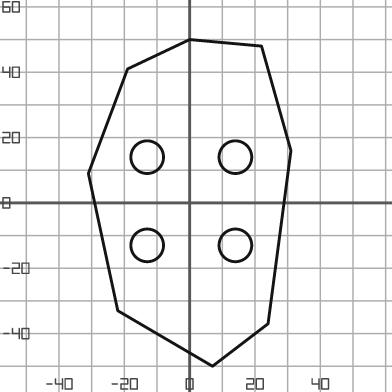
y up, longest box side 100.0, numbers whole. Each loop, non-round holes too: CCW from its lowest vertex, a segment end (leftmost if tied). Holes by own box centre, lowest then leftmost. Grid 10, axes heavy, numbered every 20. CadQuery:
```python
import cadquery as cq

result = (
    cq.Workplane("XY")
    .moveTo(7.0, -50.0)
    .lineTo(24.0, -37.0)
    .lineTo(31.0, 16.0)
    .lineTo(22.0, 48.0)
    .lineTo(0.0, 50.0)
    .lineTo(-19.0, 41.0)
    .lineTo(-31.0, 9.0)
    .lineTo(-22.0, -33.0)
    .close()
    .moveTo(-13.0, -13.0)
    .circle(5.0)
    .moveTo(14.0, -13.0)
    .circle(5.0)
    .moveTo(-13.0, 14.0)
    .circle(5.0)
    .moveTo(14.0, 14.0)
    .circle(5.0)
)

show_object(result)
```